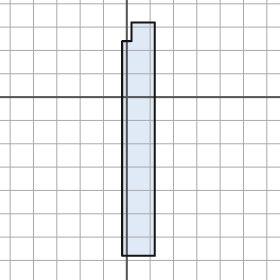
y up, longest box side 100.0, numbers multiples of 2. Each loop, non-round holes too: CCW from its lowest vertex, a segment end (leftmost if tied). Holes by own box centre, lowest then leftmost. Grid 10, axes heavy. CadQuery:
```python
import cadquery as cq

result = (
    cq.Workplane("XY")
    .moveTo(-2.0, -68.0)
    .lineTo(12.0, -68.0)
    .lineTo(12.0, 32.0)
    .lineTo(2.0, 32.0)
    .lineTo(2.0, 24.0)
    .lineTo(-2.0, 24.0)
    .close()
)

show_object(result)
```